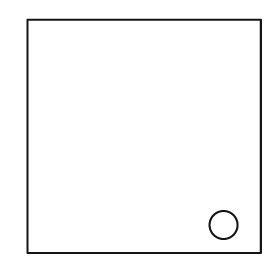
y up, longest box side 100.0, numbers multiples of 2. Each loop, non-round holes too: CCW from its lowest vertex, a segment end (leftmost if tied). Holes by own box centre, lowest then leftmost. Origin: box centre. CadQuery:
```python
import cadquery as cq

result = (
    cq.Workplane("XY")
    .moveTo(-50.0, -50.0)
    .lineTo(50.0, -50.0)
    .lineTo(50.0, 50.0)
    .lineTo(-50.0, 50.0)
    .close()
    .moveTo(34.0, -38.0)
    .circle(6.0)
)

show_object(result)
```